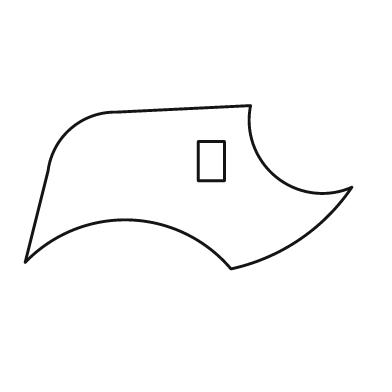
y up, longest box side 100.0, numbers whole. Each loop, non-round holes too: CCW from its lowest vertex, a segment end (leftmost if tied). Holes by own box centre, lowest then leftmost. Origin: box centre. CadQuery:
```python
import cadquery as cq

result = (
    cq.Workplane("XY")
    .moveTo(13.0, -25.0)
    .threePointArc((34.0, -16.0), (50.0, 0.0))
    .threePointArc((27.0, 3.0), (19.0, 25.0))
    .lineTo(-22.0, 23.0)
    .threePointArc((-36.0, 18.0), (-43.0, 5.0))
    .lineTo(-50.0, -23.0)
    .threePointArc((-18.0, -10.0), (13.0, -25.0))
    .close()
    .moveTo(3.0, 2.0)
    .lineTo(11.0, 2.0)
    .lineTo(11.0, 14.0)
    .lineTo(3.0, 14.0)
    .close()
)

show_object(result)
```